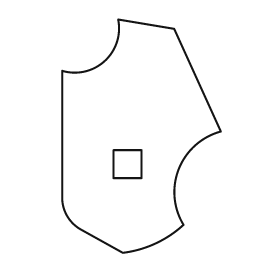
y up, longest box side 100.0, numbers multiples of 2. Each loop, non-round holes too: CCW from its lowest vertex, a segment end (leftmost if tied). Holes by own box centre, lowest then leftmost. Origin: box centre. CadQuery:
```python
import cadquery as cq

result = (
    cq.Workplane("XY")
    .moveTo(-8.0, -50.0)
    .threePointArc((6.0, -46.0), (18.0, -38.0))
    .threePointArc((16.0, -14.0), (34.0, 2.0))
    .lineTo(14.0, 46.0)
    .lineTo(-10.0, 50.0)
    .threePointArc((-16.0, 32.0), (-34.0, 28.0))
    .lineTo(-34.0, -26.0)
    .threePointArc((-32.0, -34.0), (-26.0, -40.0))
    .close()
    .moveTo(-12.0, -18.0)
    .lineTo(0.0, -18.0)
    .lineTo(0.0, -6.0)
    .lineTo(-12.0, -6.0)
    .close()
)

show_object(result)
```